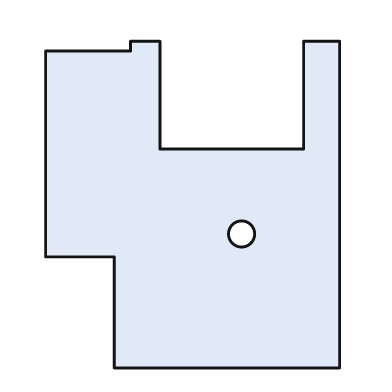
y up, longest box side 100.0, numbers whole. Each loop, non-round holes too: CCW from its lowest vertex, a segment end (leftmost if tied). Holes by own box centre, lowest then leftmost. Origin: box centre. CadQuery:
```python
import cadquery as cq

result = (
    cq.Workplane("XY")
    .moveTo(-24.0, -50.0)
    .lineTo(45.0, -50.0)
    .lineTo(45.0, 50.0)
    .lineTo(34.0, 50.0)
    .lineTo(34.0, 17.0)
    .lineTo(-10.0, 17.0)
    .lineTo(-10.0, 50.0)
    .lineTo(-19.0, 50.0)
    .lineTo(-19.0, 47.0)
    .lineTo(-45.0, 47.0)
    .lineTo(-45.0, -16.0)
    .lineTo(-24.0, -16.0)
    .close()
    .moveTo(15.0, -9.0)
    .circle(4.0)
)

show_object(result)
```